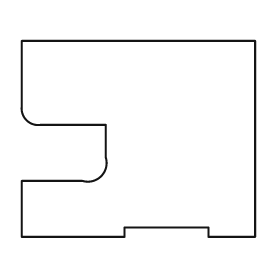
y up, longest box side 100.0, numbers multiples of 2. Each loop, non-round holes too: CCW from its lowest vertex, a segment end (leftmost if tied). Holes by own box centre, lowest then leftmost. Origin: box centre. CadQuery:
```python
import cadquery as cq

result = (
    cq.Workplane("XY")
    .moveTo(-50.0, -42.0)
    .lineTo(-6.0, -42.0)
    .lineTo(-6.0, -38.0)
    .lineTo(30.0, -38.0)
    .lineTo(30.0, -42.0)
    .lineTo(50.0, -42.0)
    .lineTo(50.0, 42.0)
    .lineTo(-50.0, 42.0)
    .lineTo(-50.0, 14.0)
    .threePointArc((-48.0, 8.0), (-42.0, 6.0))
    .lineTo(-14.0, 6.0)
    .lineTo(-14.0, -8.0)
    .threePointArc((-16.0, -16.0), (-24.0, -18.0))
    .lineTo(-50.0, -18.0)
    .close()
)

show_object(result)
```